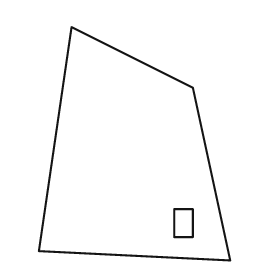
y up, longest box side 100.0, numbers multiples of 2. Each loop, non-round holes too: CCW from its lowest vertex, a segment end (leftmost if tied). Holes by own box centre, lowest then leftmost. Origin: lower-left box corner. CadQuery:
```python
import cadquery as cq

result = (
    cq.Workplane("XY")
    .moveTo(82.0, 0.0)
    .lineTo(66.0, 74.0)
    .lineTo(14.0, 100.0)
    .lineTo(0.0, 4.0)
    .close()
    .moveTo(58.0, 10.0)
    .lineTo(66.0, 10.0)
    .lineTo(66.0, 22.0)
    .lineTo(58.0, 22.0)
    .close()
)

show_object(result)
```